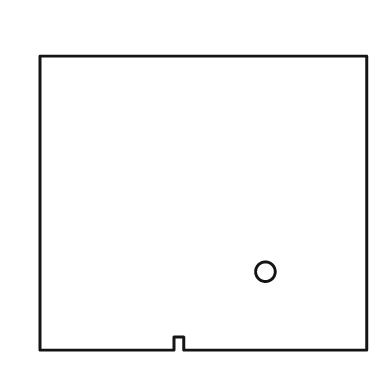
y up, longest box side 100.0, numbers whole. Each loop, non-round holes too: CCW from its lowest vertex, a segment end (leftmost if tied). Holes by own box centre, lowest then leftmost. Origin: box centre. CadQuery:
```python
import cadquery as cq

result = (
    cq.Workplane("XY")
    .moveTo(-50.0, -45.0)
    .lineTo(-9.0, -45.0)
    .lineTo(-9.0, -41.0)
    .lineTo(-6.0, -41.0)
    .lineTo(-6.0, -45.0)
    .lineTo(50.0, -45.0)
    .lineTo(50.0, 45.0)
    .lineTo(-50.0, 45.0)
    .close()
    .moveTo(19.0, -21.0)
    .circle(3.0)
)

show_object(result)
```